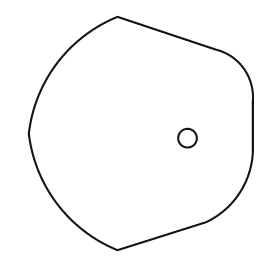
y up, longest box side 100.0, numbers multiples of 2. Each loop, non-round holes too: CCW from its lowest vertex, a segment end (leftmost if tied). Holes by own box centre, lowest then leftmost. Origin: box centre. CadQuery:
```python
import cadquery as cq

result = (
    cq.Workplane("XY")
    .moveTo(-10.0, -50.0)
    .lineTo(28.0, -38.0)
    .threePointArc((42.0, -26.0), (48.0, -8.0))
    .lineTo(48.0, 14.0)
    .threePointArc((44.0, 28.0), (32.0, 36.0))
    .lineTo(-10.0, 50.0)
    .threePointArc((-36.0, 30.0), (-48.0, 0.0))
    .threePointArc((-36.0, -30.0), (-10.0, -50.0))
    .close()
    .moveTo(20.0, -2.0)
    .circle(4.0)
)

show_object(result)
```